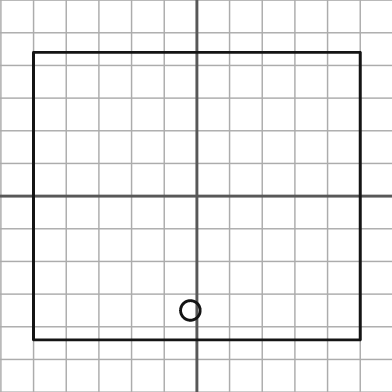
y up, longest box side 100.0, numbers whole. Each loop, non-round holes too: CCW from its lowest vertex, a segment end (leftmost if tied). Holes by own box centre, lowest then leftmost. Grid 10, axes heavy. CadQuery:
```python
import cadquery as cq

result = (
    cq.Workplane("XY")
    .moveTo(-50.0, -44.0)
    .lineTo(50.0, -44.0)
    .lineTo(50.0, 44.0)
    .lineTo(-50.0, 44.0)
    .close()
    .moveTo(-2.0, -35.0)
    .circle(3.0)
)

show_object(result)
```